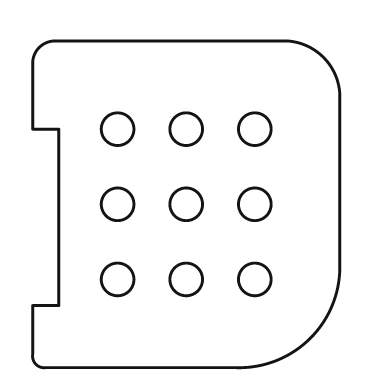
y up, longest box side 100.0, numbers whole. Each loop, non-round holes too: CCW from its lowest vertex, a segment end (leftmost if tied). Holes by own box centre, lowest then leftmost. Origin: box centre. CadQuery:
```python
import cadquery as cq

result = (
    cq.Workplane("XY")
    .moveTo(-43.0, -50.0)
    .lineTo(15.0, -50.0)
    .threePointArc((38.0, -41.0), (47.0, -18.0))
    .lineTo(47.0, 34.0)
    .threePointArc((42.0, 45.0), (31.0, 50.0))
    .lineTo(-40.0, 50.0)
    .threePointArc((-45.0, 48.0), (-47.0, 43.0))
    .lineTo(-47.0, 23.0)
    .lineTo(-39.0, 23.0)
    .lineTo(-39.0, -31.0)
    .lineTo(-47.0, -31.0)
    .lineTo(-47.0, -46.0)
    .threePointArc((-46.0, -49.0), (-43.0, -50.0))
    .close()
    .moveTo(-21.0, -23.0)
    .circle(5.0)
    .moveTo(0.0, -23.0)
    .circle(5.0)
    .moveTo(21.0, -23.0)
    .circle(5.0)
    .moveTo(-21.0, 0.0)
    .circle(5.0)
    .moveTo(0.0, 0.0)
    .circle(5.0)
    .moveTo(21.0, 0.0)
    .circle(5.0)
    .moveTo(-21.0, 23.0)
    .circle(5.0)
    .moveTo(0.0, 23.0)
    .circle(5.0)
    .moveTo(21.0, 23.0)
    .circle(5.0)
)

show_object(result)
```